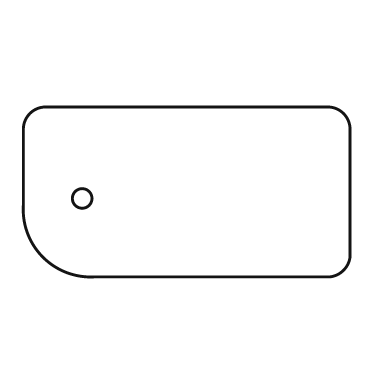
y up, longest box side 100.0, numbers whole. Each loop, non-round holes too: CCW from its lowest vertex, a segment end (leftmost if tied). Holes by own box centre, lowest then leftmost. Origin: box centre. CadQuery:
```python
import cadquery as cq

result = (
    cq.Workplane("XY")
    .moveTo(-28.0, -26.0)
    .lineTo(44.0, -26.0)
    .threePointArc((48.0, -24.0), (50.0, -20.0))
    .lineTo(50.0, 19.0)
    .threePointArc((48.0, 24.0), (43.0, 26.0))
    .lineTo(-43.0, 26.0)
    .threePointArc((-48.0, 24.0), (-50.0, 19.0))
    .lineTo(-50.0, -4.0)
    .threePointArc((-44.0, -20.0), (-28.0, -26.0))
    .close()
    .moveTo(-32.0, -2.0)
    .circle(3.0)
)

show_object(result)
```